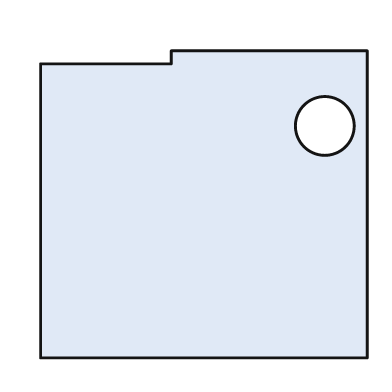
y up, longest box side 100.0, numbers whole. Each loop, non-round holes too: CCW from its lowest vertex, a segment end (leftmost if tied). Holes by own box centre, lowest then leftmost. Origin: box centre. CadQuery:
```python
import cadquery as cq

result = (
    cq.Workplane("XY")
    .moveTo(-50.0, -47.0)
    .lineTo(50.0, -47.0)
    .lineTo(50.0, 47.0)
    .lineTo(-10.0, 47.0)
    .lineTo(-10.0, 43.0)
    .lineTo(-50.0, 43.0)
    .close()
    .moveTo(37.0, 24.0)
    .circle(9.0)
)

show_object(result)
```